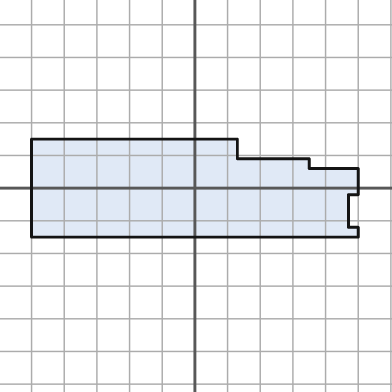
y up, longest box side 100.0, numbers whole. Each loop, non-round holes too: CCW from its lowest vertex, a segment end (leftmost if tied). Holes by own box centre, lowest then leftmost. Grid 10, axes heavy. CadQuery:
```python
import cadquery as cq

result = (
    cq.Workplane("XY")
    .moveTo(-50.0, -15.0)
    .lineTo(50.0, -15.0)
    .lineTo(50.0, -12.0)
    .lineTo(47.0, -12.0)
    .lineTo(47.0, -2.0)
    .lineTo(50.0, -2.0)
    .lineTo(50.0, 6.0)
    .lineTo(35.0, 6.0)
    .lineTo(35.0, 9.0)
    .lineTo(13.0, 9.0)
    .lineTo(13.0, 15.0)
    .lineTo(-50.0, 15.0)
    .close()
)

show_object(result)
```